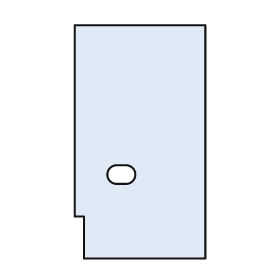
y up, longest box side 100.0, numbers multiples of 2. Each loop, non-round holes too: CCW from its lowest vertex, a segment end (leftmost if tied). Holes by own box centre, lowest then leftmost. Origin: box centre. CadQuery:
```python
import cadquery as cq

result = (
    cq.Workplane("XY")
    .moveTo(-24.0, -50.0)
    .lineTo(28.0, -50.0)
    .lineTo(28.0, 50.0)
    .lineTo(-28.0, 50.0)
    .lineTo(-28.0, -32.0)
    .lineTo(-24.0, -32.0)
    .close()
    .moveTo(-10.0, -18.0)
    .lineTo(-6.0, -18.0)
    .threePointArc((-2.0, -14.0), (-6.0, -10.0))
    .lineTo(-10.0, -10.0)
    .threePointArc((-14.0, -14.0), (-10.0, -18.0))
    .close()
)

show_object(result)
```